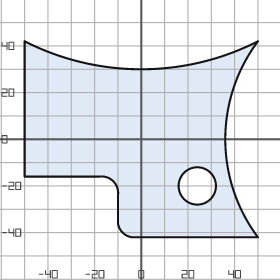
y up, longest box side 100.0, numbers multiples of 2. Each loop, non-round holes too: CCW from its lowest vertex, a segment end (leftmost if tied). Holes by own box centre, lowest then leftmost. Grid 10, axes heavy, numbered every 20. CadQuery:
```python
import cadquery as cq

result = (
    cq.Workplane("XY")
    .moveTo(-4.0, -42.0)
    .lineTo(50.0, -42.0)
    .threePointArc((36.0, 0.0), (50.0, 42.0))
    .threePointArc((0.0, 30.0), (-50.0, 42.0))
    .lineTo(-50.0, -16.0)
    .lineTo(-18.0, -16.0)
    .threePointArc((-12.0, -18.0), (-10.0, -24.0))
    .lineTo(-10.0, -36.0)
    .threePointArc((-8.0, -40.0), (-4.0, -42.0))
    .close()
    .moveTo(24.0, -20.0)
    .circle(8.0)
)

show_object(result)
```